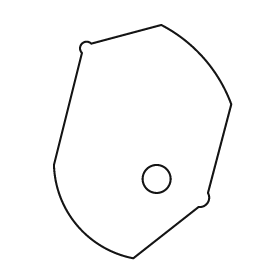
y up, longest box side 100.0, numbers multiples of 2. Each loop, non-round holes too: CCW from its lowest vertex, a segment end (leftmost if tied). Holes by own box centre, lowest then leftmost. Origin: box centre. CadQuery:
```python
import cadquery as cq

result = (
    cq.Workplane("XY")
    .moveTo(-4.0, -50.0)
    .lineTo(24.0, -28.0)
    .threePointArc((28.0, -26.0), (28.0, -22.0))
    .lineTo(38.0, 16.0)
    .threePointArc((26.0, 36.0), (8.0, 50.0))
    .lineTo(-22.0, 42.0)
    .threePointArc((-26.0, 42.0), (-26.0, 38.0))
    .lineTo(-38.0, -10.0)
    .threePointArc((-28.0, -36.0), (-4.0, -50.0))
    .close()
    .moveTo(6.0, -16.0)
    .circle(6.0)
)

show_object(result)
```